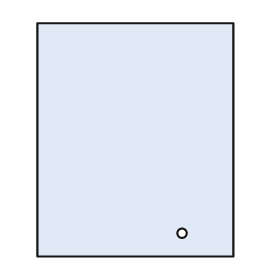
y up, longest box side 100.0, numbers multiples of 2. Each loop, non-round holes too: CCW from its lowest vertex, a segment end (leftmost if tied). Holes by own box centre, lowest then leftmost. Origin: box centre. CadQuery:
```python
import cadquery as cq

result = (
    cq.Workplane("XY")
    .moveTo(-42.0, -50.0)
    .lineTo(42.0, -50.0)
    .lineTo(42.0, 50.0)
    .lineTo(-42.0, 50.0)
    .close()
    .moveTo(20.0, -40.0)
    .circle(2.0)
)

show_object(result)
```